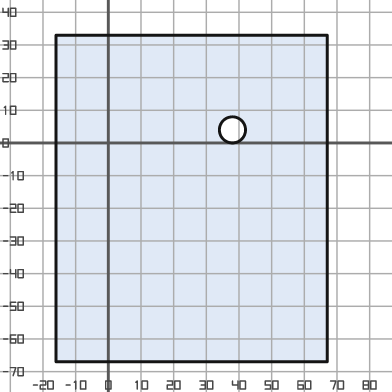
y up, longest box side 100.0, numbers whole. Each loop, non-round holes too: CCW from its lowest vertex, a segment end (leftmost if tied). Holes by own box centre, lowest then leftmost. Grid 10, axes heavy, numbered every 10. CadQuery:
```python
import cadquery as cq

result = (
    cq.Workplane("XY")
    .moveTo(-16.0, -67.0)
    .lineTo(67.0, -67.0)
    .lineTo(67.0, 33.0)
    .lineTo(-16.0, 33.0)
    .close()
    .moveTo(38.0, 4.0)
    .circle(4.0)
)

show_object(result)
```